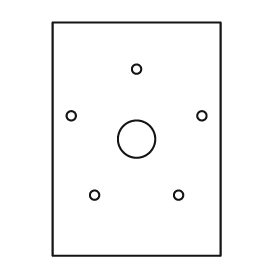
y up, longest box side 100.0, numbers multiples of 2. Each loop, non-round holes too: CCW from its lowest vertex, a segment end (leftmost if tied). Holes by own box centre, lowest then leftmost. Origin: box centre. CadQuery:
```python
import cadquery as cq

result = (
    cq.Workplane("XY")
    .moveTo(-36.0, -50.0)
    .lineTo(36.0, -50.0)
    .lineTo(36.0, 50.0)
    .lineTo(-36.0, 50.0)
    .close()
    .moveTo(-18.0, -24.0)
    .circle(2.0)
    .moveTo(18.0, -24.0)
    .circle(2.0)
    .moveTo(0.0, 0.0)
    .circle(8.0)
    .moveTo(-28.0, 10.0)
    .circle(2.0)
    .moveTo(28.0, 10.0)
    .circle(2.0)
    .moveTo(0.0, 30.0)
    .circle(2.0)
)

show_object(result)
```